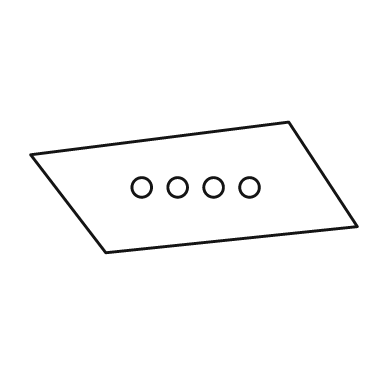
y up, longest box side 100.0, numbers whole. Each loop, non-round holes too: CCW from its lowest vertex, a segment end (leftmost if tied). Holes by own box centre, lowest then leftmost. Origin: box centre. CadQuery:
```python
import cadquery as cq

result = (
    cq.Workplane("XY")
    .moveTo(-27.0, -20.0)
    .lineTo(50.0, -12.0)
    .lineTo(29.0, 20.0)
    .lineTo(-50.0, 10.0)
    .close()
    .moveTo(-16.0, 0.0)
    .circle(3.0)
    .moveTo(-5.0, 0.0)
    .circle(3.0)
    .moveTo(6.0, 0.0)
    .circle(3.0)
    .moveTo(17.0, 0.0)
    .circle(3.0)
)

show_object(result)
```